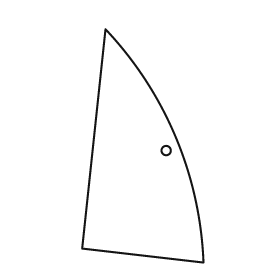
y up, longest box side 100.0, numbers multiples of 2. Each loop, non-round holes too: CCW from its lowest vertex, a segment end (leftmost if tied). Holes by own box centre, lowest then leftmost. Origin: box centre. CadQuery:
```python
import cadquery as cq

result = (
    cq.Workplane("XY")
    .moveTo(26.0, -50.0)
    .threePointArc((14.0, 4.0), (-16.0, 50.0))
    .lineTo(-26.0, -44.0)
    .close()
    .moveTo(10.0, -2.0)
    .circle(2.0)
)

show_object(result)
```